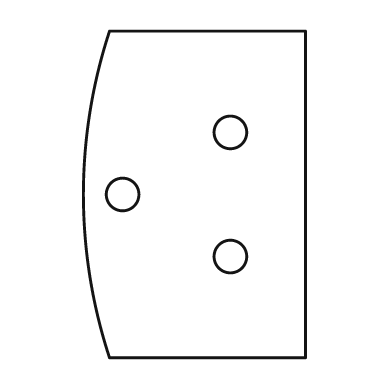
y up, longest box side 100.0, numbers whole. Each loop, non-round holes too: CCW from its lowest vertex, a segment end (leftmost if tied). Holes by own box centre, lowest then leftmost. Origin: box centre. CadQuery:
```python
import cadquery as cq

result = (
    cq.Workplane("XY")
    .moveTo(-26.0, -50.0)
    .lineTo(34.0, -50.0)
    .lineTo(34.0, 50.0)
    .lineTo(-26.0, 50.0)
    .threePointArc((-34.0, 0.0), (-26.0, -50.0))
    .close()
    .moveTo(11.0, -19.0)
    .circle(5.0)
    .moveTo(-22.0, 0.0)
    .circle(5.0)
    .moveTo(11.0, 19.0)
    .circle(5.0)
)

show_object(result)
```